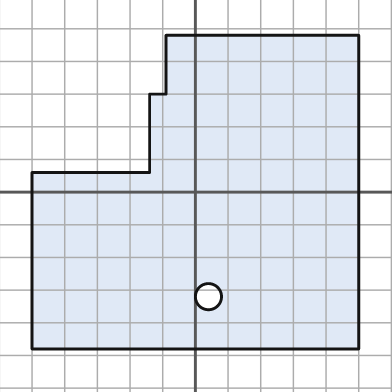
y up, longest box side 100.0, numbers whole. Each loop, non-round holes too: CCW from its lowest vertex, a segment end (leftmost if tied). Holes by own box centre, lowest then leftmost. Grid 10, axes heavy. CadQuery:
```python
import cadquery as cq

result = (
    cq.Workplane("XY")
    .moveTo(-50.0, -48.0)
    .lineTo(50.0, -48.0)
    .lineTo(50.0, 48.0)
    .lineTo(-9.0, 48.0)
    .lineTo(-9.0, 30.0)
    .lineTo(-14.0, 30.0)
    .lineTo(-14.0, 6.0)
    .lineTo(-50.0, 6.0)
    .close()
    .moveTo(4.0, -32.0)
    .circle(4.0)
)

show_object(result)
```